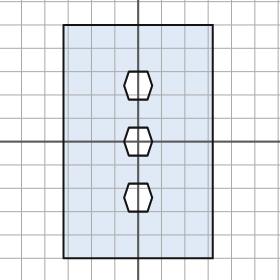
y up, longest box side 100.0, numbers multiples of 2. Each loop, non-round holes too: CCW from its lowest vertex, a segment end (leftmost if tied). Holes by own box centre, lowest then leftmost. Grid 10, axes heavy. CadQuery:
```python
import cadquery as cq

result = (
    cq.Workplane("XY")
    .moveTo(-32.0, -50.0)
    .lineTo(32.0, -50.0)
    .lineTo(32.0, 50.0)
    .lineTo(-32.0, 50.0)
    .close()
    .moveTo(-4.0, -30.0)
    .lineTo(4.0, -30.0)
    .lineTo(6.0, -24.0)
    .lineTo(4.0, -18.0)
    .lineTo(-4.0, -18.0)
    .lineTo(-6.0, -24.0)
    .close()
    .moveTo(-4.0, -6.0)
    .lineTo(4.0, -6.0)
    .lineTo(6.0, 0.0)
    .lineTo(4.0, 6.0)
    .lineTo(-4.0, 6.0)
    .lineTo(-6.0, 0.0)
    .close()
    .moveTo(-4.0, 18.0)
    .lineTo(4.0, 18.0)
    .lineTo(6.0, 24.0)
    .lineTo(4.0, 30.0)
    .lineTo(-4.0, 30.0)
    .lineTo(-6.0, 24.0)
    .close()
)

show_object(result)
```